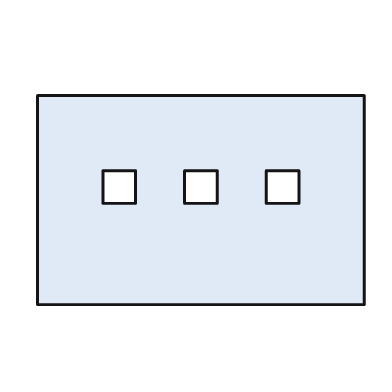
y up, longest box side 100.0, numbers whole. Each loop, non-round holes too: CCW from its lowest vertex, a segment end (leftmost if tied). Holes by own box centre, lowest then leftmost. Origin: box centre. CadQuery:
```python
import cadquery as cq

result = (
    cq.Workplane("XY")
    .moveTo(-50.0, -32.0)
    .lineTo(50.0, -32.0)
    .lineTo(50.0, 32.0)
    .lineTo(-50.0, 32.0)
    .close()
    .moveTo(-30.0, -1.0)
    .lineTo(-20.0, -1.0)
    .lineTo(-20.0, 9.0)
    .lineTo(-30.0, 9.0)
    .close()
    .moveTo(-5.0, -1.0)
    .lineTo(5.0, -1.0)
    .lineTo(5.0, 9.0)
    .lineTo(-5.0, 9.0)
    .close()
    .moveTo(20.0, -1.0)
    .lineTo(30.0, -1.0)
    .lineTo(30.0, 9.0)
    .lineTo(20.0, 9.0)
    .close()
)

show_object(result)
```